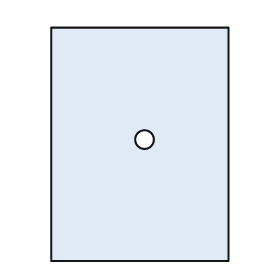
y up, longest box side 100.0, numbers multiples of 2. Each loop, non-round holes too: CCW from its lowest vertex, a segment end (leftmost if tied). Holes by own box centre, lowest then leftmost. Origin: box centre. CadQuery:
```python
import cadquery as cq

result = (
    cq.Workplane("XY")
    .moveTo(-38.0, -50.0)
    .lineTo(38.0, -50.0)
    .lineTo(38.0, 50.0)
    .lineTo(-38.0, 50.0)
    .close()
    .moveTo(2.0, 2.0)
    .circle(4.0)
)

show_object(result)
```